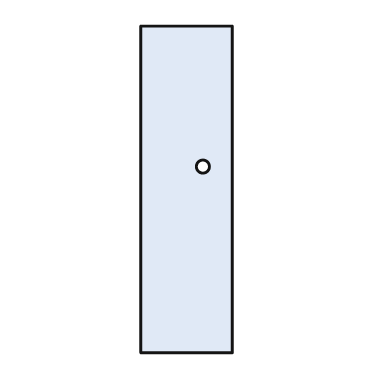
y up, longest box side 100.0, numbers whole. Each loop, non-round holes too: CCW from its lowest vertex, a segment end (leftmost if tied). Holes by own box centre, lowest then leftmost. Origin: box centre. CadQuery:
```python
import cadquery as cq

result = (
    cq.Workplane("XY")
    .moveTo(-14.0, -50.0)
    .lineTo(14.0, -50.0)
    .lineTo(14.0, 50.0)
    .lineTo(-14.0, 50.0)
    .close()
    .moveTo(5.0, 7.0)
    .circle(2.0)
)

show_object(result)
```